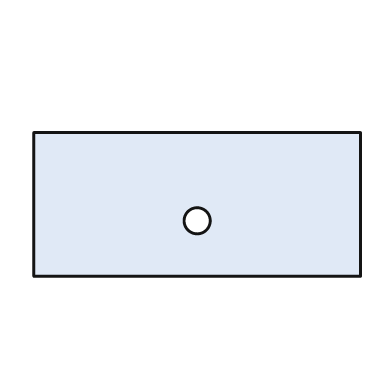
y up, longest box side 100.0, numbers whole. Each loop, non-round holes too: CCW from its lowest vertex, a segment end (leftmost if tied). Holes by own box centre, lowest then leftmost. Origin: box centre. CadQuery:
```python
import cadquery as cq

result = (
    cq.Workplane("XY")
    .moveTo(-50.0, -22.0)
    .lineTo(50.0, -22.0)
    .lineTo(50.0, 22.0)
    .lineTo(-50.0, 22.0)
    .close()
    .moveTo(0.0, -5.0)
    .circle(4.0)
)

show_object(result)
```